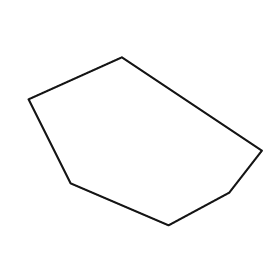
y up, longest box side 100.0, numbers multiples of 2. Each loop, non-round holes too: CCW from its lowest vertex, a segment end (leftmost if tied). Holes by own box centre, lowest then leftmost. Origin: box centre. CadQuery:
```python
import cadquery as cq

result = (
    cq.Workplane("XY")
    .moveTo(10.0, -36.0)
    .lineTo(36.0, -22.0)
    .lineTo(50.0, -4.0)
    .lineTo(-10.0, 36.0)
    .lineTo(-50.0, 18.0)
    .lineTo(-32.0, -18.0)
    .close()
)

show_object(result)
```